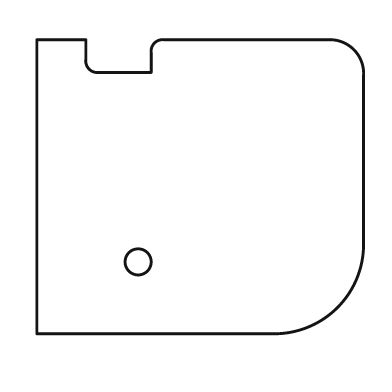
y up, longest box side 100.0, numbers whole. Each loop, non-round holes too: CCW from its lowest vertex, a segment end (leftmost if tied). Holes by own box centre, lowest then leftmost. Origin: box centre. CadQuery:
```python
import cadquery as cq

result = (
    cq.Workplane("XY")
    .moveTo(-50.0, -45.0)
    .lineTo(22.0, -45.0)
    .threePointArc((42.0, -37.0), (50.0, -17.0))
    .lineTo(50.0, 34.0)
    .threePointArc((47.0, 42.0), (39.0, 45.0))
    .lineTo(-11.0, 45.0)
    .threePointArc((-14.0, 44.0), (-15.0, 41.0))
    .lineTo(-15.0, 35.0)
    .lineTo(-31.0, 35.0)
    .threePointArc((-34.0, 36.0), (-35.0, 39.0))
    .lineTo(-35.0, 45.0)
    .lineTo(-50.0, 45.0)
    .close()
    .moveTo(-19.0, -23.0)
    .circle(4.0)
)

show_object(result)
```